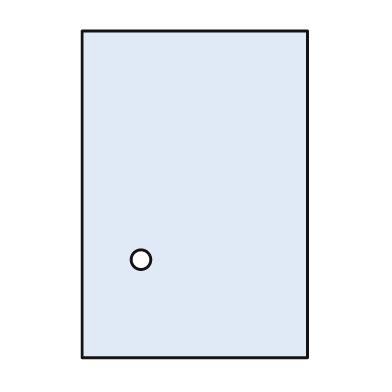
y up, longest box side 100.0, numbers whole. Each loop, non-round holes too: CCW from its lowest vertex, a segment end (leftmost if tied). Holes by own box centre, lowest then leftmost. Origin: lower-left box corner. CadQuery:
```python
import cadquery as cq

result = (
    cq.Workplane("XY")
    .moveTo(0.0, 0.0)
    .lineTo(69.0, 0.0)
    .lineTo(69.0, 100.0)
    .lineTo(0.0, 100.0)
    .close()
    .moveTo(18.0, 30.0)
    .circle(3.0)
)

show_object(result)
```